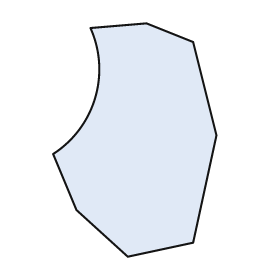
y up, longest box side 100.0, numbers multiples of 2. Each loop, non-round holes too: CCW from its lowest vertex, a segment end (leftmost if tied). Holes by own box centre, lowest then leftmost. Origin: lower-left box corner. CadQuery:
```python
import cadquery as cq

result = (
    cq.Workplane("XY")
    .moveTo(32.0, 0.0)
    .lineTo(60.0, 6.0)
    .lineTo(70.0, 52.0)
    .lineTo(60.0, 92.0)
    .lineTo(40.0, 100.0)
    .lineTo(16.0, 98.0)
    .threePointArc((18.0, 68.0), (0.0, 44.0))
    .lineTo(10.0, 20.0)
    .close()
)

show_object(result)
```